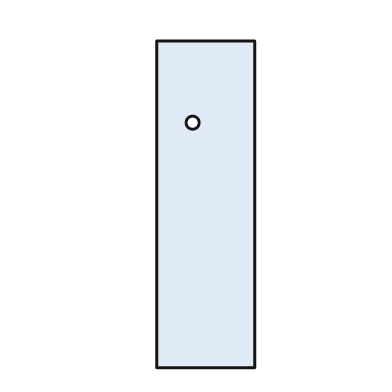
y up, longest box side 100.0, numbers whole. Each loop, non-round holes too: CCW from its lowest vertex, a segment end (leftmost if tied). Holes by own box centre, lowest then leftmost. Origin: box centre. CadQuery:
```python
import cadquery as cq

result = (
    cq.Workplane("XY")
    .moveTo(-15.0, -50.0)
    .lineTo(15.0, -50.0)
    .lineTo(15.0, 50.0)
    .lineTo(-15.0, 50.0)
    .close()
    .moveTo(-4.0, 25.0)
    .circle(2.0)
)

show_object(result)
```